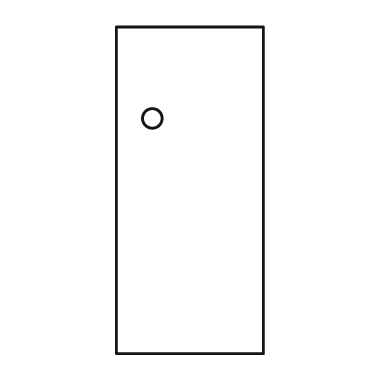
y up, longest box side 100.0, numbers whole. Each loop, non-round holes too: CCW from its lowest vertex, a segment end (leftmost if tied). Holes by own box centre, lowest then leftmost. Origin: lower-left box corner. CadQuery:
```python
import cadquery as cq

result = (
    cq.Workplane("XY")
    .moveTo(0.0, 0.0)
    .lineTo(45.0, 0.0)
    .lineTo(45.0, 100.0)
    .lineTo(0.0, 100.0)
    .close()
    .moveTo(11.0, 72.0)
    .circle(3.0)
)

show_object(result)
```